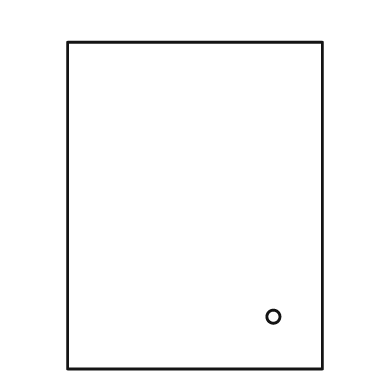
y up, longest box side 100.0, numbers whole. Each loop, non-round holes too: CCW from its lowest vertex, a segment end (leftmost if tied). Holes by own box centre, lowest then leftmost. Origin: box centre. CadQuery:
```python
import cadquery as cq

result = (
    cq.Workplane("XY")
    .moveTo(-39.0, -50.0)
    .lineTo(39.0, -50.0)
    .lineTo(39.0, 50.0)
    .lineTo(-39.0, 50.0)
    .close()
    .moveTo(24.0, -34.0)
    .circle(2.0)
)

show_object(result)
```